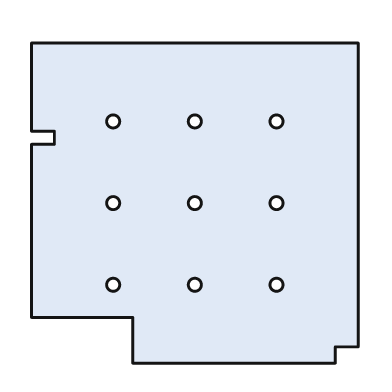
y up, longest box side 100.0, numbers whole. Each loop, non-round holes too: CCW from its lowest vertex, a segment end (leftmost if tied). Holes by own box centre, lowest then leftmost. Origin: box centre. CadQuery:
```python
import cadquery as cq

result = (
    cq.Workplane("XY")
    .moveTo(-19.0, -49.0)
    .lineTo(43.0, -49.0)
    .lineTo(43.0, -44.0)
    .lineTo(50.0, -44.0)
    .lineTo(50.0, 49.0)
    .lineTo(-50.0, 49.0)
    .lineTo(-50.0, 22.0)
    .lineTo(-43.0, 22.0)
    .lineTo(-43.0, 18.0)
    .lineTo(-50.0, 18.0)
    .lineTo(-50.0, -35.0)
    .lineTo(-19.0, -35.0)
    .close()
    .moveTo(-25.0, -25.0)
    .circle(2.0)
    .moveTo(0.0, -25.0)
    .circle(2.0)
    .moveTo(25.0, -25.0)
    .circle(2.0)
    .moveTo(-25.0, 0.0)
    .circle(2.0)
    .moveTo(0.0, 0.0)
    .circle(2.0)
    .moveTo(25.0, 0.0)
    .circle(2.0)
    .moveTo(-25.0, 25.0)
    .circle(2.0)
    .moveTo(0.0, 25.0)
    .circle(2.0)
    .moveTo(25.0, 25.0)
    .circle(2.0)
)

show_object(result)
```